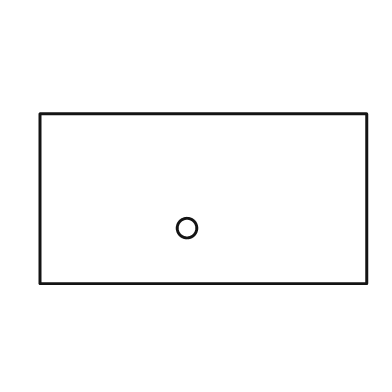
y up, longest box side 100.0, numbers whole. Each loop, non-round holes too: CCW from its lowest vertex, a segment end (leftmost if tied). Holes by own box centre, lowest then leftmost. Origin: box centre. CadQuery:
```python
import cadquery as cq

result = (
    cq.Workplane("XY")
    .moveTo(-50.0, -26.0)
    .lineTo(50.0, -26.0)
    .lineTo(50.0, 26.0)
    .lineTo(-50.0, 26.0)
    .close()
    .moveTo(-5.0, -9.0)
    .circle(3.0)
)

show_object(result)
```